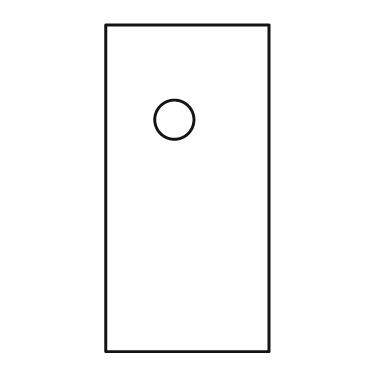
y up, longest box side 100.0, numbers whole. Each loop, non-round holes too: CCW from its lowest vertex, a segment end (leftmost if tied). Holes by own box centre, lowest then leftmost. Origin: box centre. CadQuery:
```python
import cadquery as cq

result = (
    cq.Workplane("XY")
    .moveTo(-25.0, -50.0)
    .lineTo(25.0, -50.0)
    .lineTo(25.0, 50.0)
    .lineTo(-25.0, 50.0)
    .close()
    .moveTo(-4.0, 21.0)
    .circle(6.0)
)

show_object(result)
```